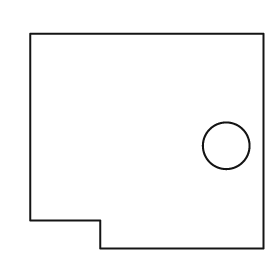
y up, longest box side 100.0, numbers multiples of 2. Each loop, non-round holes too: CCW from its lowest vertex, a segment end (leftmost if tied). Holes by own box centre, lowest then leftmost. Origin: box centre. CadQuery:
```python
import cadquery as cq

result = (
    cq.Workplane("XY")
    .moveTo(-20.0, -46.0)
    .lineTo(50.0, -46.0)
    .lineTo(50.0, 46.0)
    .lineTo(-50.0, 46.0)
    .lineTo(-50.0, -34.0)
    .lineTo(-20.0, -34.0)
    .close()
    .moveTo(34.0, -2.0)
    .circle(10.0)
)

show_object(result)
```